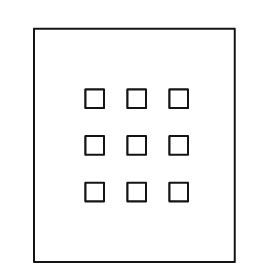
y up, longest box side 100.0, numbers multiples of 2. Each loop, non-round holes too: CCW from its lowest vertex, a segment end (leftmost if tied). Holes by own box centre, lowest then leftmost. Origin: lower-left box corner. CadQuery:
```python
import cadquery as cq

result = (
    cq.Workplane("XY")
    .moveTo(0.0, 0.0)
    .lineTo(86.0, 0.0)
    .lineTo(86.0, 100.0)
    .lineTo(0.0, 100.0)
    .close()
    .moveTo(22.0, 26.0)
    .lineTo(30.0, 26.0)
    .lineTo(30.0, 34.0)
    .lineTo(22.0, 34.0)
    .close()
    .moveTo(40.0, 26.0)
    .lineTo(48.0, 26.0)
    .lineTo(48.0, 34.0)
    .lineTo(40.0, 34.0)
    .close()
    .moveTo(58.0, 26.0)
    .lineTo(66.0, 26.0)
    .lineTo(66.0, 34.0)
    .lineTo(58.0, 34.0)
    .close()
    .moveTo(22.0, 46.0)
    .lineTo(30.0, 46.0)
    .lineTo(30.0, 54.0)
    .lineTo(22.0, 54.0)
    .close()
    .moveTo(40.0, 46.0)
    .lineTo(48.0, 46.0)
    .lineTo(48.0, 54.0)
    .lineTo(40.0, 54.0)
    .close()
    .moveTo(58.0, 46.0)
    .lineTo(66.0, 46.0)
    .lineTo(66.0, 54.0)
    .lineTo(58.0, 54.0)
    .close()
    .moveTo(22.0, 66.0)
    .lineTo(30.0, 66.0)
    .lineTo(30.0, 74.0)
    .lineTo(22.0, 74.0)
    .close()
    .moveTo(40.0, 66.0)
    .lineTo(48.0, 66.0)
    .lineTo(48.0, 74.0)
    .lineTo(40.0, 74.0)
    .close()
    .moveTo(58.0, 66.0)
    .lineTo(66.0, 66.0)
    .lineTo(66.0, 74.0)
    .lineTo(58.0, 74.0)
    .close()
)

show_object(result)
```